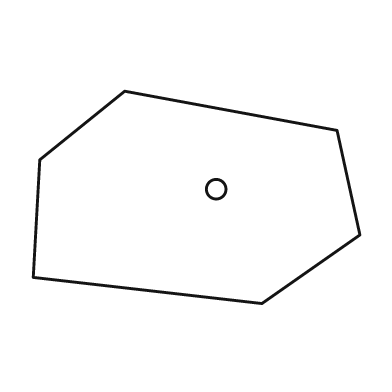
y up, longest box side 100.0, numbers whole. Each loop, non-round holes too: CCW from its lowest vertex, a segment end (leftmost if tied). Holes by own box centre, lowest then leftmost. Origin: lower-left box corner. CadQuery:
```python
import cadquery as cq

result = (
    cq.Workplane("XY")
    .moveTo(70.0, 0.0)
    .lineTo(100.0, 21.0)
    .lineTo(93.0, 53.0)
    .lineTo(28.0, 65.0)
    .lineTo(2.0, 44.0)
    .lineTo(0.0, 8.0)
    .close()
    .moveTo(56.0, 35.0)
    .circle(3.0)
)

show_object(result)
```